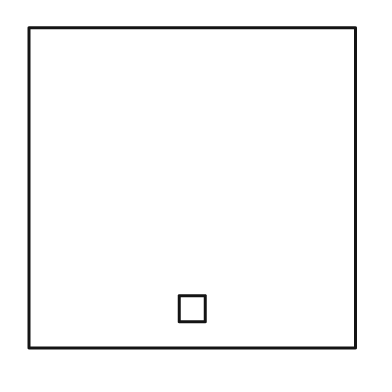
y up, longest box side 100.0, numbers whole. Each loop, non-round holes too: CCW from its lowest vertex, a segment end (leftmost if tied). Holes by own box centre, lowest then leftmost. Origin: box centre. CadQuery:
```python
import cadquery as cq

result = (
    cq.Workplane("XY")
    .moveTo(-50.0, -49.0)
    .lineTo(50.0, -49.0)
    .lineTo(50.0, 49.0)
    .lineTo(-50.0, 49.0)
    .close()
    .moveTo(-4.0, -41.0)
    .lineTo(4.0, -41.0)
    .lineTo(4.0, -33.0)
    .lineTo(-4.0, -33.0)
    .close()
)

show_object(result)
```